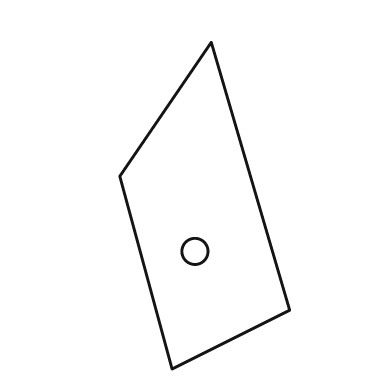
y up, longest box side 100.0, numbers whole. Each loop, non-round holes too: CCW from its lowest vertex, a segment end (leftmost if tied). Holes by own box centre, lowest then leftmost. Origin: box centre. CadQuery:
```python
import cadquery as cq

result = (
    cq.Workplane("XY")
    .moveTo(-10.0, -50.0)
    .lineTo(26.0, -32.0)
    .lineTo(2.0, 50.0)
    .lineTo(-26.0, 9.0)
    .close()
    .moveTo(-3.0, -14.0)
    .circle(4.0)
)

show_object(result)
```